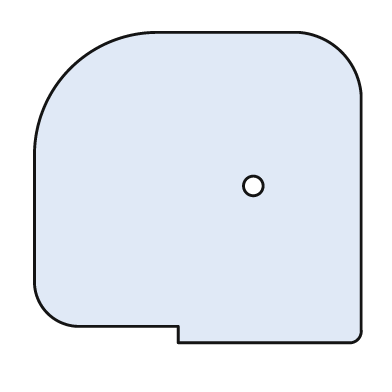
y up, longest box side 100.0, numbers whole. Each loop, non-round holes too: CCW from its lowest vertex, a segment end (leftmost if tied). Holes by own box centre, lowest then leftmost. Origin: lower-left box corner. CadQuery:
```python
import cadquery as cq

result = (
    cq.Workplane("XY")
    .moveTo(44.0, 0.0)
    .lineTo(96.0, 0.0)
    .threePointArc((99.0, 1.0), (100.0, 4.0))
    .lineTo(100.0, 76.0)
    .threePointArc((94.0, 89.0), (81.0, 95.0))
    .lineTo(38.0, 95.0)
    .threePointArc((11.0, 84.0), (0.0, 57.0))
    .lineTo(0.0, 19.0)
    .threePointArc((4.0, 9.0), (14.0, 5.0))
    .lineTo(44.0, 5.0)
    .close()
    .moveTo(67.0, 48.0)
    .circle(3.0)
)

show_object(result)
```